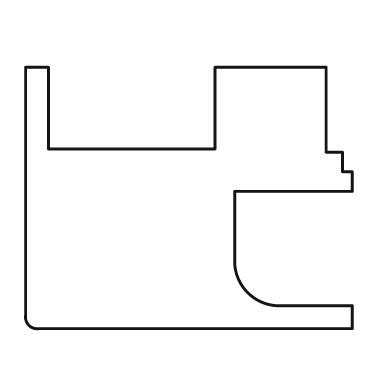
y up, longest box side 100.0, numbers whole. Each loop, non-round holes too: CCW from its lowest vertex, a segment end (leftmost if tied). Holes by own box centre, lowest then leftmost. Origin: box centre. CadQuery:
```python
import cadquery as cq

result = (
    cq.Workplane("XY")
    .moveTo(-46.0, -40.0)
    .lineTo(50.0, -40.0)
    .lineTo(50.0, -33.0)
    .lineTo(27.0, -33.0)
    .threePointArc((18.0, -29.0), (14.0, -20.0))
    .lineTo(14.0, 2.0)
    .lineTo(50.0, 2.0)
    .lineTo(50.0, 8.0)
    .lineTo(47.0, 8.0)
    .lineTo(47.0, 14.0)
    .lineTo(42.0, 14.0)
    .lineTo(42.0, 40.0)
    .lineTo(8.0, 40.0)
    .lineTo(8.0, 15.0)
    .lineTo(-43.0, 15.0)
    .lineTo(-43.0, 40.0)
    .lineTo(-50.0, 40.0)
    .lineTo(-50.0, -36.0)
    .threePointArc((-49.0, -39.0), (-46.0, -40.0))
    .close()
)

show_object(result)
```